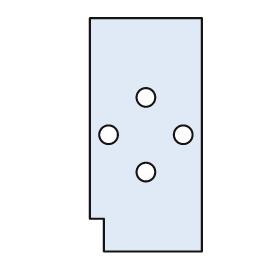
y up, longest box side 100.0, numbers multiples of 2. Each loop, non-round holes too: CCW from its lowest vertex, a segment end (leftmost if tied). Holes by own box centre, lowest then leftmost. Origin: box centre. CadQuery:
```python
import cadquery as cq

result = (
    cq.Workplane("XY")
    .moveTo(-18.0, -50.0)
    .lineTo(24.0, -50.0)
    .lineTo(24.0, 50.0)
    .lineTo(-24.0, 50.0)
    .lineTo(-24.0, -36.0)
    .lineTo(-18.0, -36.0)
    .close()
    .moveTo(0.0, -16.0)
    .circle(4.0)
    .moveTo(-16.0, 0.0)
    .circle(4.0)
    .moveTo(16.0, 0.0)
    .circle(4.0)
    .moveTo(0.0, 16.0)
    .circle(4.0)
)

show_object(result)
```